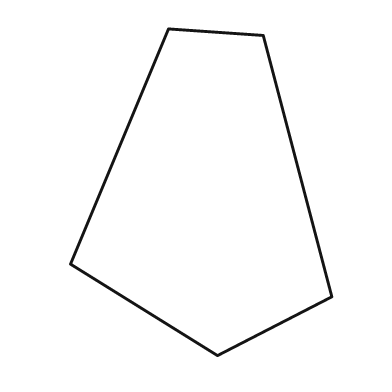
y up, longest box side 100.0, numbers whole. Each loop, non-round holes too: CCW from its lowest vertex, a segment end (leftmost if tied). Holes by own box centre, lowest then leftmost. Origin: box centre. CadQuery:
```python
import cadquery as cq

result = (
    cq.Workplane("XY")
    .moveTo(5.0, -50.0)
    .lineTo(40.0, -32.0)
    .lineTo(19.0, 48.0)
    .lineTo(-10.0, 50.0)
    .lineTo(-40.0, -22.0)
    .close()
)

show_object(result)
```